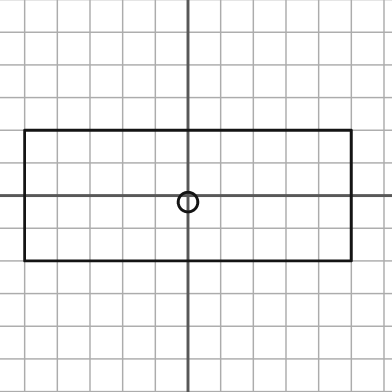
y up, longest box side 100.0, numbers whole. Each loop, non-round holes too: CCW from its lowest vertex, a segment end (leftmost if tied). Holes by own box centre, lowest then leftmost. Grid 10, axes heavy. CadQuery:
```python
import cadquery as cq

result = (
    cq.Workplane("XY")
    .moveTo(-50.0, -20.0)
    .lineTo(50.0, -20.0)
    .lineTo(50.0, 20.0)
    .lineTo(-50.0, 20.0)
    .close()
    .moveTo(0.0, -2.0)
    .circle(3.0)
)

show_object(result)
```